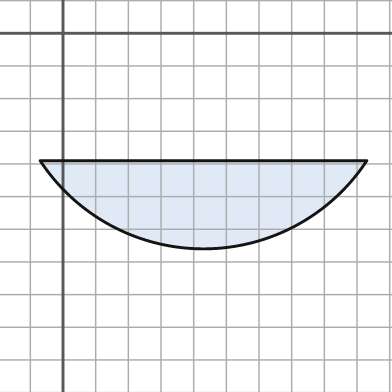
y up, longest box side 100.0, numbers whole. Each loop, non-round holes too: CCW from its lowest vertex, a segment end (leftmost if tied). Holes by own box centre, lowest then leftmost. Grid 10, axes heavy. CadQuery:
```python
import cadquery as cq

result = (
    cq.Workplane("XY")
    .moveTo(-7.0, -39.0)
    .threePointArc((43.0, -66.0), (93.0, -39.0))
    .close()
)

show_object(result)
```